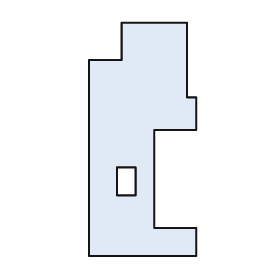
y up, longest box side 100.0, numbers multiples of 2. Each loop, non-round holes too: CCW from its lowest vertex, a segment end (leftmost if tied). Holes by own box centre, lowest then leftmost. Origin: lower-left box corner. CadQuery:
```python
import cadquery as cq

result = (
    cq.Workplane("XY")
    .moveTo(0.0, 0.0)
    .lineTo(46.0, 0.0)
    .lineTo(46.0, 12.0)
    .lineTo(28.0, 12.0)
    .lineTo(28.0, 54.0)
    .lineTo(46.0, 54.0)
    .lineTo(46.0, 68.0)
    .lineTo(42.0, 68.0)
    .lineTo(42.0, 100.0)
    .lineTo(14.0, 100.0)
    .lineTo(14.0, 84.0)
    .lineTo(0.0, 84.0)
    .close()
    .moveTo(12.0, 26.0)
    .lineTo(20.0, 26.0)
    .lineTo(20.0, 38.0)
    .lineTo(12.0, 38.0)
    .close()
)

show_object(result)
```